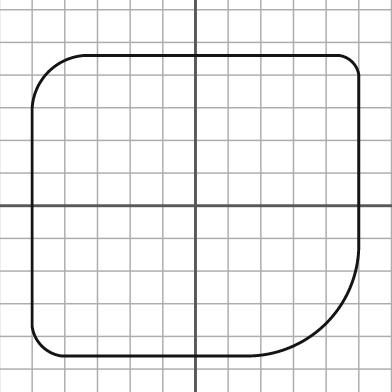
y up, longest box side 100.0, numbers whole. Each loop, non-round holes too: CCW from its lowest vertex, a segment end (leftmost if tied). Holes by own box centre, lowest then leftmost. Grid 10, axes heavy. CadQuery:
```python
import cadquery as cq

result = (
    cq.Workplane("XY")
    .moveTo(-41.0, -46.0)
    .lineTo(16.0, -46.0)
    .threePointArc((40.0, -36.0), (50.0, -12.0))
    .lineTo(50.0, 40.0)
    .threePointArc((48.0, 44.0), (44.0, 46.0))
    .lineTo(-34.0, 46.0)
    .threePointArc((-45.0, 41.0), (-50.0, 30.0))
    .lineTo(-50.0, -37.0)
    .threePointArc((-47.0, -43.0), (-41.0, -46.0))
    .close()
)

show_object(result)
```